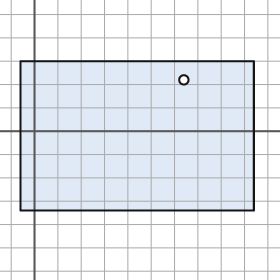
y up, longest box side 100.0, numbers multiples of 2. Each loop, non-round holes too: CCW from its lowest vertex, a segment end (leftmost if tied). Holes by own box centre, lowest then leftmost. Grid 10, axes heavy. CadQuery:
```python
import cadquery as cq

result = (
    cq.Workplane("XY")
    .moveTo(-6.0, -34.0)
    .lineTo(94.0, -34.0)
    .lineTo(94.0, 30.0)
    .lineTo(-6.0, 30.0)
    .close()
    .moveTo(64.0, 22.0)
    .circle(2.0)
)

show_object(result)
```